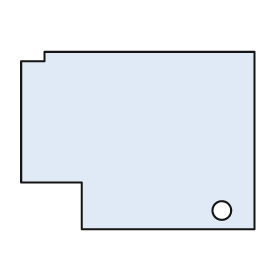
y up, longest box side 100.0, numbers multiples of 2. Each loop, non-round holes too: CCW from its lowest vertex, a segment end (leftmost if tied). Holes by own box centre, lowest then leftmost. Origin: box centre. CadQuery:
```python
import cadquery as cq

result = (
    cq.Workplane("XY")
    .moveTo(-24.0, -38.0)
    .lineTo(50.0, -38.0)
    .lineTo(50.0, 38.0)
    .lineTo(-40.0, 38.0)
    .lineTo(-40.0, 34.0)
    .lineTo(-50.0, 34.0)
    .lineTo(-50.0, -18.0)
    .lineTo(-24.0, -18.0)
    .close()
    .moveTo(36.0, -30.0)
    .circle(4.0)
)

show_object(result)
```